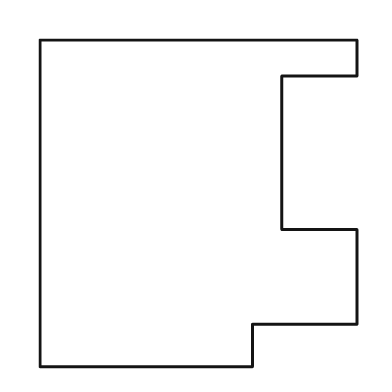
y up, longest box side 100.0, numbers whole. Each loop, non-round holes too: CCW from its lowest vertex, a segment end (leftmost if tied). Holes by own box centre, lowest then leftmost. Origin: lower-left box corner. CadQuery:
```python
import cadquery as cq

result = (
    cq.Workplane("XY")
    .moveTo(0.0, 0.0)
    .lineTo(65.0, 0.0)
    .lineTo(65.0, 13.0)
    .lineTo(97.0, 13.0)
    .lineTo(97.0, 42.0)
    .lineTo(74.0, 42.0)
    .lineTo(74.0, 89.0)
    .lineTo(97.0, 89.0)
    .lineTo(97.0, 100.0)
    .lineTo(0.0, 100.0)
    .close()
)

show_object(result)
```